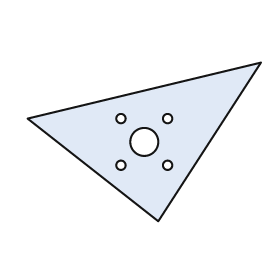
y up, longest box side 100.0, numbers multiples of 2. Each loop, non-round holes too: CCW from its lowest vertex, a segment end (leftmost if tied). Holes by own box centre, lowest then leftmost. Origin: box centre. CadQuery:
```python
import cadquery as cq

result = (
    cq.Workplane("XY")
    .moveTo(6.0, -34.0)
    .lineTo(50.0, 34.0)
    .lineTo(-50.0, 10.0)
    .close()
    .moveTo(-10.0, -10.0)
    .circle(2.0)
    .moveTo(10.0, -10.0)
    .circle(2.0)
    .moveTo(0.0, 0.0)
    .circle(6.0)
    .moveTo(-10.0, 10.0)
    .circle(2.0)
    .moveTo(10.0, 10.0)
    .circle(2.0)
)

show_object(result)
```